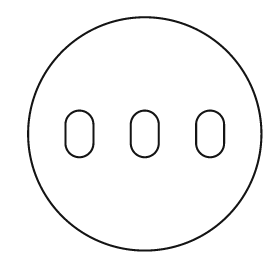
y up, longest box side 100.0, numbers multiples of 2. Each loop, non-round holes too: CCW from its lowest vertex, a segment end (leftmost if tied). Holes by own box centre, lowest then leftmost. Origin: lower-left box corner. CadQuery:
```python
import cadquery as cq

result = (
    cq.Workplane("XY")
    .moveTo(50.0, 50.0)
    .circle(50.0)
    .moveTo(16.0, 46.0)
    .threePointArc((22.0, 40.0), (28.0, 46.0))
    .lineTo(28.0, 54.0)
    .threePointArc((22.0, 60.0), (16.0, 54.0))
    .close()
    .moveTo(44.0, 46.0)
    .threePointArc((50.0, 40.0), (56.0, 46.0))
    .lineTo(56.0, 54.0)
    .threePointArc((50.0, 60.0), (44.0, 54.0))
    .close()
    .moveTo(72.0, 46.0)
    .threePointArc((78.0, 40.0), (84.0, 46.0))
    .lineTo(84.0, 54.0)
    .threePointArc((78.0, 60.0), (72.0, 54.0))
    .close()
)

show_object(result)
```